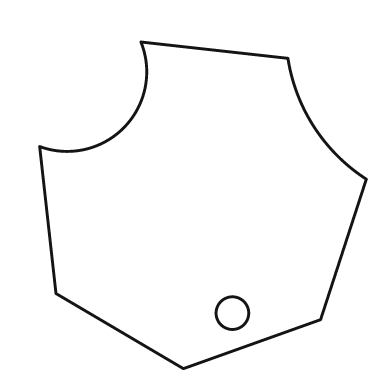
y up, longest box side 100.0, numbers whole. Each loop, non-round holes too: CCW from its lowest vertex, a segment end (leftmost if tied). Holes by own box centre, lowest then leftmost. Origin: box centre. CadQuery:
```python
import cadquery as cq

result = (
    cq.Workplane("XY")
    .moveTo(-6.0, -50.0)
    .lineTo(36.0, -35.0)
    .lineTo(50.0, 8.0)
    .threePointArc((34.0, 24.0), (26.0, 45.0))
    .lineTo(-19.0, 50.0)
    .threePointArc((-24.0, 24.0), (-50.0, 18.0))
    .lineTo(-45.0, -27.0)
    .close()
    .moveTo(9.0, -33.0)
    .circle(5.0)
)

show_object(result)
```